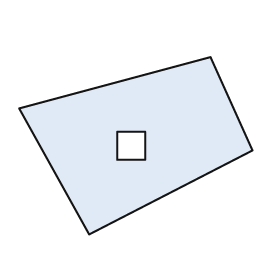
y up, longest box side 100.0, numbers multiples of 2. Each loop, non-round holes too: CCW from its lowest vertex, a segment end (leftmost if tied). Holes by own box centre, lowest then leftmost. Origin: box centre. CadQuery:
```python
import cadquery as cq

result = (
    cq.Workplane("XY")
    .moveTo(-20.0, -38.0)
    .lineTo(50.0, -2.0)
    .lineTo(32.0, 38.0)
    .lineTo(-50.0, 16.0)
    .close()
    .moveTo(-8.0, -6.0)
    .lineTo(4.0, -6.0)
    .lineTo(4.0, 6.0)
    .lineTo(-8.0, 6.0)
    .close()
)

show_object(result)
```